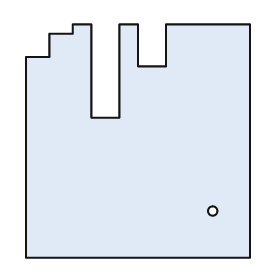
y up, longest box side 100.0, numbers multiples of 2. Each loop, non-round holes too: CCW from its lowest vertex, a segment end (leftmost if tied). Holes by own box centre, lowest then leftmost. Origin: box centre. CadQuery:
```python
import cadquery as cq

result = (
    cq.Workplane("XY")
    .moveTo(-48.0, -50.0)
    .lineTo(48.0, -50.0)
    .lineTo(48.0, 50.0)
    .lineTo(12.0, 50.0)
    .lineTo(12.0, 32.0)
    .lineTo(0.0, 32.0)
    .lineTo(0.0, 50.0)
    .lineTo(-8.0, 50.0)
    .lineTo(-8.0, 10.0)
    .lineTo(-20.0, 10.0)
    .lineTo(-20.0, 50.0)
    .lineTo(-28.0, 50.0)
    .lineTo(-28.0, 46.0)
    .lineTo(-38.0, 46.0)
    .lineTo(-38.0, 36.0)
    .lineTo(-48.0, 36.0)
    .close()
    .moveTo(32.0, -30.0)
    .circle(2.0)
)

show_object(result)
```